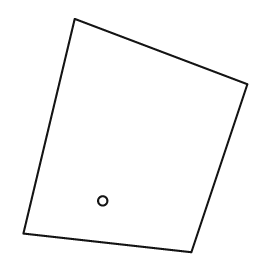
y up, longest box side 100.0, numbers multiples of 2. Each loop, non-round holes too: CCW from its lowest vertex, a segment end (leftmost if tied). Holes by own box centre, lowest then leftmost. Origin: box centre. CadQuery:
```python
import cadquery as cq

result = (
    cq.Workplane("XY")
    .moveTo(24.0, -50.0)
    .lineTo(48.0, 22.0)
    .lineTo(-26.0, 50.0)
    .lineTo(-48.0, -42.0)
    .close()
    .moveTo(-14.0, -28.0)
    .circle(2.0)
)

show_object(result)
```